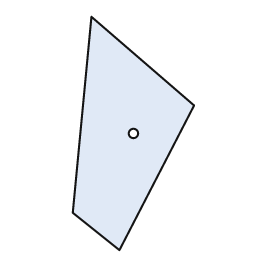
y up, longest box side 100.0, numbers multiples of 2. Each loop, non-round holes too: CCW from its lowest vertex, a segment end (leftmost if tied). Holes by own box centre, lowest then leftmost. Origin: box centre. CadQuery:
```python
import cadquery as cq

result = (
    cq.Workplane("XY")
    .moveTo(-6.0, -50.0)
    .lineTo(26.0, 12.0)
    .lineTo(-18.0, 50.0)
    .lineTo(-26.0, -34.0)
    .close()
    .moveTo(0.0, 0.0)
    .circle(2.0)
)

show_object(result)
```